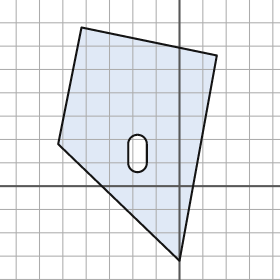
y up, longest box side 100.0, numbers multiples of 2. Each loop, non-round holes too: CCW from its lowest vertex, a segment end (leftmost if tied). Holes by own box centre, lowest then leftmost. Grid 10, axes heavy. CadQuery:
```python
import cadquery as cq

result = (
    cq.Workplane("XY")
    .moveTo(0.0, -32.0)
    .lineTo(16.0, 56.0)
    .lineTo(-42.0, 68.0)
    .lineTo(-52.0, 18.0)
    .close()
    .moveTo(-22.0, 10.0)
    .threePointArc((-18.0, 6.0), (-14.0, 10.0))
    .lineTo(-14.0, 18.0)
    .threePointArc((-18.0, 22.0), (-22.0, 18.0))
    .close()
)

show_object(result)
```